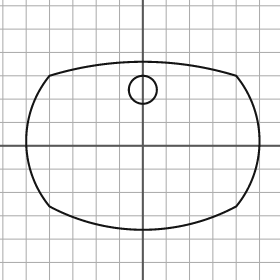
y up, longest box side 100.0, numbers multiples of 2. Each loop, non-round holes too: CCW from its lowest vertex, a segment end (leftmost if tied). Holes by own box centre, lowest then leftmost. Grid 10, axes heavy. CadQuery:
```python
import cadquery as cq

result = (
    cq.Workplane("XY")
    .moveTo(-40.0, -26.0)
    .threePointArc((0.0, -36.0), (40.0, -26.0))
    .threePointArc((50.0, 2.0), (40.0, 30.0))
    .threePointArc((0.0, 36.0), (-40.0, 30.0))
    .threePointArc((-50.0, 2.0), (-40.0, -26.0))
    .close()
    .moveTo(0.0, 24.0)
    .circle(6.0)
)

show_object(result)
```